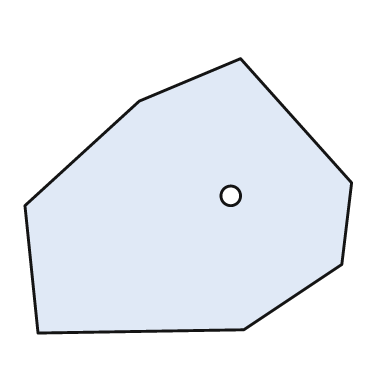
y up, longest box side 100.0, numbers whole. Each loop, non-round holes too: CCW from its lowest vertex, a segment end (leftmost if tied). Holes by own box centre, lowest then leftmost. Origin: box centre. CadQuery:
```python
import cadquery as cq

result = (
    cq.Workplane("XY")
    .moveTo(-46.0, -42.0)
    .lineTo(17.0, -41.0)
    .lineTo(47.0, -21.0)
    .lineTo(50.0, 4.0)
    .lineTo(16.0, 42.0)
    .lineTo(-15.0, 29.0)
    .lineTo(-50.0, -3.0)
    .close()
    .moveTo(13.0, 0.0)
    .circle(3.0)
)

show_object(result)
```